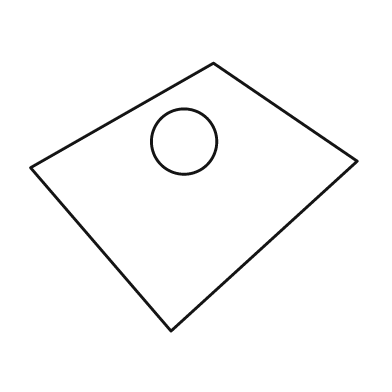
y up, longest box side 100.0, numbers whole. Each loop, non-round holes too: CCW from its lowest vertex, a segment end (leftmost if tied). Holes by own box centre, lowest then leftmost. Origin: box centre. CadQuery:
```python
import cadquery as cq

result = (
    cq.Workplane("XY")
    .moveTo(-7.0, -41.0)
    .lineTo(50.0, 11.0)
    .lineTo(6.0, 41.0)
    .lineTo(-50.0, 9.0)
    .close()
    .moveTo(-3.0, 17.0)
    .circle(10.0)
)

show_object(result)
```